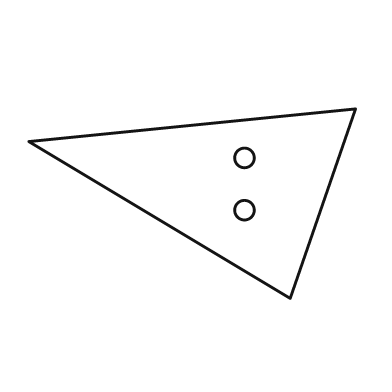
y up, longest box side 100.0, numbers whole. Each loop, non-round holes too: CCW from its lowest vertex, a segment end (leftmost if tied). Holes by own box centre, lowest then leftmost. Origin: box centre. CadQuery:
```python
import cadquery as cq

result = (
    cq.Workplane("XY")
    .moveTo(30.0, -29.0)
    .lineTo(50.0, 29.0)
    .lineTo(-50.0, 19.0)
    .close()
    .moveTo(16.0, -2.0)
    .circle(3.0)
    .moveTo(16.0, 14.0)
    .circle(3.0)
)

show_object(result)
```